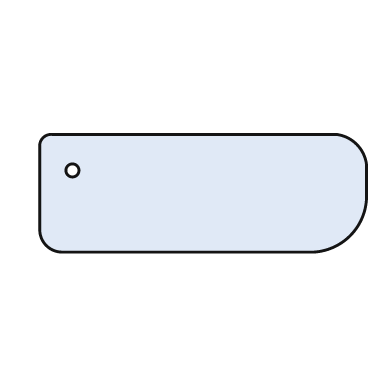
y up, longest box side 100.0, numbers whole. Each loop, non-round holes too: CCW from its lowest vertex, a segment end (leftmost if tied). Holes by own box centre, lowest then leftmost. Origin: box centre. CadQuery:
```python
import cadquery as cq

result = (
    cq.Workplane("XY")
    .moveTo(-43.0, -18.0)
    .lineTo(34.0, -18.0)
    .threePointArc((45.0, -13.0), (50.0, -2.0))
    .lineTo(50.0, 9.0)
    .threePointArc((47.0, 15.0), (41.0, 18.0))
    .lineTo(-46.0, 18.0)
    .threePointArc((-49.0, 17.0), (-50.0, 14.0))
    .lineTo(-50.0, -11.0)
    .threePointArc((-48.0, -16.0), (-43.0, -18.0))
    .close()
    .moveTo(-40.0, 7.0)
    .circle(2.0)
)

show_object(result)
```